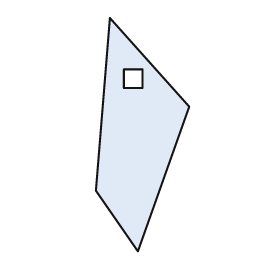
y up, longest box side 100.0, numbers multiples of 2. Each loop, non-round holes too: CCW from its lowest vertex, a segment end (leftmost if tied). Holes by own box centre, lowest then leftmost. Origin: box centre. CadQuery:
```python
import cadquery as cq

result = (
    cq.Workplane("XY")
    .moveTo(-2.0, -50.0)
    .lineTo(20.0, 12.0)
    .lineTo(-14.0, 50.0)
    .lineTo(-20.0, -24.0)
    .close()
    .moveTo(-8.0, 20.0)
    .lineTo(0.0, 20.0)
    .lineTo(0.0, 28.0)
    .lineTo(-8.0, 28.0)
    .close()
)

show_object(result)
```